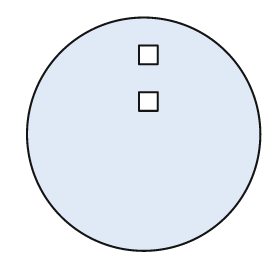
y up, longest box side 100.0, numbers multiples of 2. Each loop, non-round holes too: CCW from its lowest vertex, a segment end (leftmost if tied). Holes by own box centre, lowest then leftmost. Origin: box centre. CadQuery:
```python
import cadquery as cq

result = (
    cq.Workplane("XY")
    .moveTo(0.0, 0.0)
    .circle(50.0)
    .moveTo(-2.0, 10.0)
    .lineTo(6.0, 10.0)
    .lineTo(6.0, 18.0)
    .lineTo(-2.0, 18.0)
    .close()
    .moveTo(-2.0, 30.0)
    .lineTo(6.0, 30.0)
    .lineTo(6.0, 38.0)
    .lineTo(-2.0, 38.0)
    .close()
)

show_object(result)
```